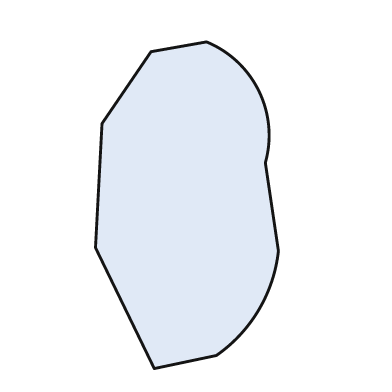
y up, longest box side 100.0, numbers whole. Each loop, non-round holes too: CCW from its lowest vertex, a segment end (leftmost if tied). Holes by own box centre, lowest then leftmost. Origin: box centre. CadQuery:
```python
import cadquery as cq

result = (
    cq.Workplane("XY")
    .moveTo(-10.0, -50.0)
    .lineTo(9.0, -46.0)
    .threePointArc((22.0, -32.0), (28.0, -14.0))
    .lineTo(24.0, 13.0)
    .threePointArc((22.0, 35.0), (6.0, 50.0))
    .lineTo(-11.0, 47.0)
    .lineTo(-26.0, 25.0)
    .lineTo(-28.0, -13.0)
    .close()
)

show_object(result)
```